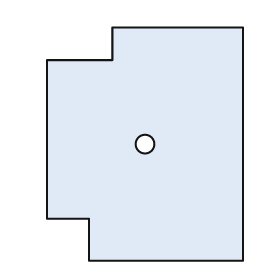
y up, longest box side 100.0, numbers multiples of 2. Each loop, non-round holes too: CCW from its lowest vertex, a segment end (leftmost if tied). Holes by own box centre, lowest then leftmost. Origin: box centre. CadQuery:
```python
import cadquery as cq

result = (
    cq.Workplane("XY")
    .moveTo(-24.0, -50.0)
    .lineTo(42.0, -50.0)
    .lineTo(42.0, 50.0)
    .lineTo(-14.0, 50.0)
    .lineTo(-14.0, 36.0)
    .lineTo(-42.0, 36.0)
    .lineTo(-42.0, -32.0)
    .lineTo(-24.0, -32.0)
    .close()
    .moveTo(0.0, 0.0)
    .circle(4.0)
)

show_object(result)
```